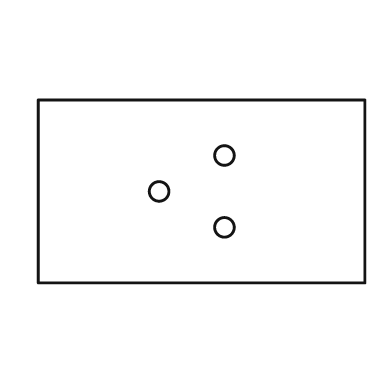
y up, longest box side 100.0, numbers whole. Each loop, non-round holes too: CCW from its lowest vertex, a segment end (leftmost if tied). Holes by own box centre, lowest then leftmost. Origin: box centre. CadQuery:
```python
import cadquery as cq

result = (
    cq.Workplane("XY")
    .moveTo(-50.0, -28.0)
    .lineTo(50.0, -28.0)
    .lineTo(50.0, 28.0)
    .lineTo(-50.0, 28.0)
    .close()
    .moveTo(7.0, -11.0)
    .circle(3.0)
    .moveTo(-13.0, 0.0)
    .circle(3.0)
    .moveTo(7.0, 11.0)
    .circle(3.0)
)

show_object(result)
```